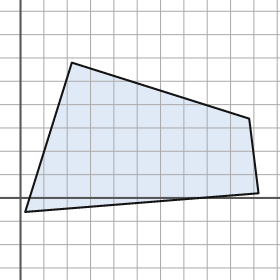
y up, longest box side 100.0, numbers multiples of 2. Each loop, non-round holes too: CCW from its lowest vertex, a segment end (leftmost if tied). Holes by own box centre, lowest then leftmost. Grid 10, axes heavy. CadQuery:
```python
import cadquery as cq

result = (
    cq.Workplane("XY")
    .moveTo(2.0, -6.0)
    .lineTo(102.0, 2.0)
    .lineTo(98.0, 34.0)
    .lineTo(22.0, 58.0)
    .close()
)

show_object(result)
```